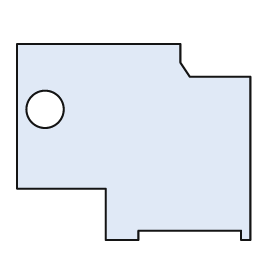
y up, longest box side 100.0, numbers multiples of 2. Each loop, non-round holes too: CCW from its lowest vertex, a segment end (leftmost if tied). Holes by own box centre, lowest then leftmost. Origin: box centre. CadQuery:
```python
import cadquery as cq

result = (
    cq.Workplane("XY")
    .moveTo(-12.0, -42.0)
    .lineTo(2.0, -42.0)
    .lineTo(2.0, -38.0)
    .lineTo(46.0, -38.0)
    .lineTo(46.0, -42.0)
    .lineTo(50.0, -42.0)
    .lineTo(50.0, 28.0)
    .lineTo(24.0, 28.0)
    .lineTo(20.0, 34.0)
    .lineTo(20.0, 42.0)
    .lineTo(-50.0, 42.0)
    .lineTo(-50.0, -20.0)
    .lineTo(-12.0, -20.0)
    .close()
    .moveTo(-38.0, 14.0)
    .circle(8.0)
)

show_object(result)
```